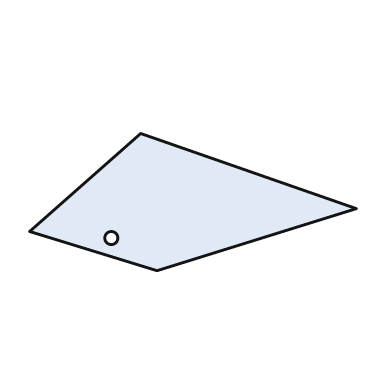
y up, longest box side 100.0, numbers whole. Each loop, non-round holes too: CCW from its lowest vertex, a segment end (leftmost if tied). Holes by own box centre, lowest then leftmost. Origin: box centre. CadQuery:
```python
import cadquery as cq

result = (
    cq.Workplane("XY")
    .moveTo(-11.0, -21.0)
    .lineTo(50.0, -2.0)
    .lineTo(-16.0, 21.0)
    .lineTo(-50.0, -9.0)
    .close()
    .moveTo(-25.0, -11.0)
    .circle(2.0)
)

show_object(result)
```